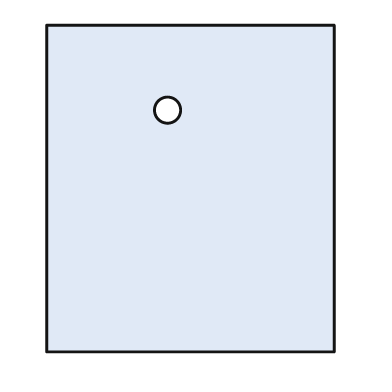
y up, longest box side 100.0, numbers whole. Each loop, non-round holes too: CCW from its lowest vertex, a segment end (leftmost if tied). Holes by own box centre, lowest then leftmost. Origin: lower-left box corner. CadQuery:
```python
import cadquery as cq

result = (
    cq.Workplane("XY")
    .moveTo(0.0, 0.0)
    .lineTo(88.0, 0.0)
    .lineTo(88.0, 100.0)
    .lineTo(0.0, 100.0)
    .close()
    .moveTo(37.0, 74.0)
    .circle(4.0)
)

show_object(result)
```